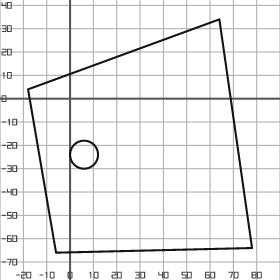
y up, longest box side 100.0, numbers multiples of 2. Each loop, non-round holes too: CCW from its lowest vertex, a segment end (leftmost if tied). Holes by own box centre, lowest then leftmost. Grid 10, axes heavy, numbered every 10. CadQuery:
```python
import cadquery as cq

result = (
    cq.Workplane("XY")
    .moveTo(-6.0, -66.0)
    .lineTo(78.0, -64.0)
    .lineTo(64.0, 34.0)
    .lineTo(-18.0, 4.0)
    .close()
    .moveTo(6.0, -24.0)
    .circle(6.0)
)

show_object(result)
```